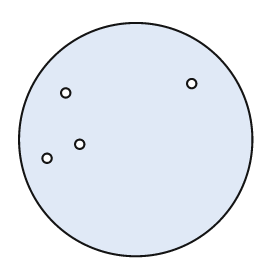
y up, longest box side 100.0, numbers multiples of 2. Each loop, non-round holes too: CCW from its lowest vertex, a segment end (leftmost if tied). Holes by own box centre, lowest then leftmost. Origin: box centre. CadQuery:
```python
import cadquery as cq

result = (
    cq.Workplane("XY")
    .moveTo(0.0, 0.0)
    .circle(50.0)
    .moveTo(-38.0, -8.0)
    .circle(2.0)
    .moveTo(-24.0, -2.0)
    .circle(2.0)
    .moveTo(-30.0, 20.0)
    .circle(2.0)
    .moveTo(24.0, 24.0)
    .circle(2.0)
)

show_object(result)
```